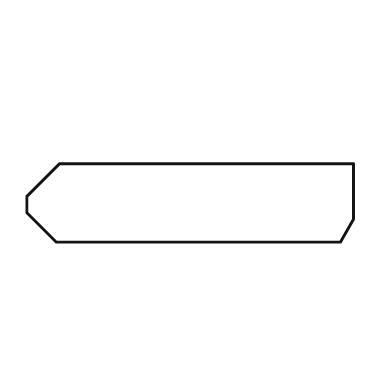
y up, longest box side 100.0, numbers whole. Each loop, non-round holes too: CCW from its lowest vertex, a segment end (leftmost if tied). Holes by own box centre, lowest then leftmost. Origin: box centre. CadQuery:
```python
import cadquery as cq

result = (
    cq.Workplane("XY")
    .moveTo(-41.0, -12.0)
    .lineTo(46.0, -12.0)
    .lineTo(50.0, -5.0)
    .lineTo(50.0, 12.0)
    .lineTo(-40.0, 12.0)
    .lineTo(-50.0, 2.0)
    .lineTo(-50.0, -3.0)
    .close()
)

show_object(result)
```